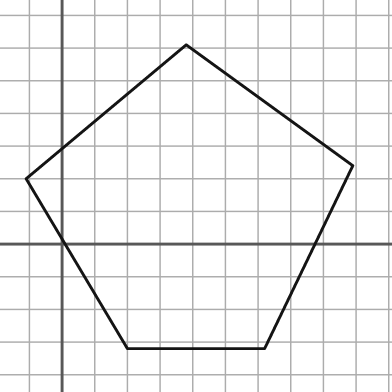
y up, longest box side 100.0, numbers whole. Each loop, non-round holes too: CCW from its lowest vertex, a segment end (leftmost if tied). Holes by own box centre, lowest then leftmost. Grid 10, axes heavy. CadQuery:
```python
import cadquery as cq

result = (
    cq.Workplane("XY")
    .moveTo(20.0, -32.0)
    .lineTo(62.0, -32.0)
    .lineTo(89.0, 24.0)
    .lineTo(38.0, 61.0)
    .lineTo(-11.0, 20.0)
    .close()
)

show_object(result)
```